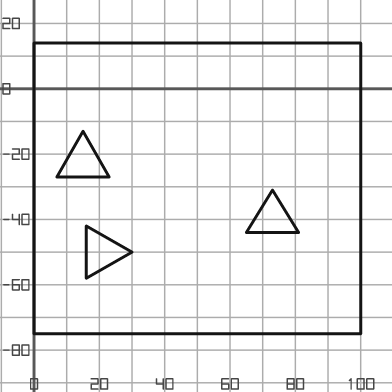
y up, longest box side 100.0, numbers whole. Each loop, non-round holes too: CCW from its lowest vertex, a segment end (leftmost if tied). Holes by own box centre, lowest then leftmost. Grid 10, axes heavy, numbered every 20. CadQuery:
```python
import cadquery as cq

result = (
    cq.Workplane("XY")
    .moveTo(0.0, -75.0)
    .lineTo(100.0, -75.0)
    .lineTo(100.0, 14.0)
    .lineTo(0.0, 14.0)
    .close()
    .moveTo(16.0, -58.0)
    .lineTo(30.0, -50.0)
    .lineTo(16.0, -42.0)
    .close()
    .moveTo(65.0, -44.0)
    .lineTo(81.0, -44.0)
    .lineTo(73.0, -31.0)
    .close()
    .moveTo(7.0, -27.0)
    .lineTo(23.0, -27.0)
    .lineTo(15.0, -13.0)
    .close()
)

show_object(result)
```